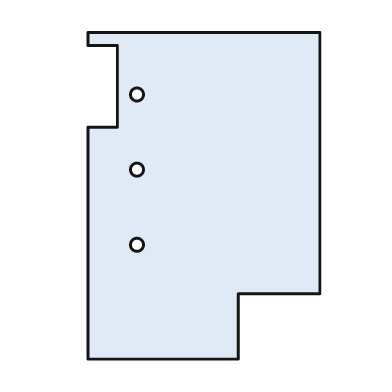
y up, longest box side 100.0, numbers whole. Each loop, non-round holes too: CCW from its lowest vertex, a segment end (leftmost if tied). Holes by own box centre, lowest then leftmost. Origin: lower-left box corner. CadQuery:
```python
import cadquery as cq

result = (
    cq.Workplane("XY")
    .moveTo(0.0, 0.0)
    .lineTo(46.0, 0.0)
    .lineTo(46.0, 20.0)
    .lineTo(71.0, 20.0)
    .lineTo(71.0, 100.0)
    .lineTo(0.0, 100.0)
    .lineTo(0.0, 96.0)
    .lineTo(9.0, 96.0)
    .lineTo(9.0, 71.0)
    .lineTo(0.0, 71.0)
    .close()
    .moveTo(15.0, 35.0)
    .circle(2.0)
    .moveTo(15.0, 58.0)
    .circle(2.0)
    .moveTo(15.0, 81.0)
    .circle(2.0)
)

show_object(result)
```